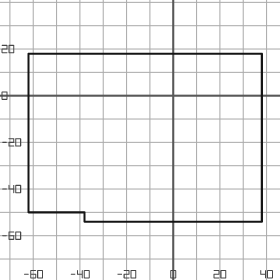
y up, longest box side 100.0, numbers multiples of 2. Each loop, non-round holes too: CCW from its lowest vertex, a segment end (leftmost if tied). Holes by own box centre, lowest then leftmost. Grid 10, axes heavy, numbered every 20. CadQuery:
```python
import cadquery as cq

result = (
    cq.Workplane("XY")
    .moveTo(-38.0, -54.0)
    .lineTo(38.0, -54.0)
    .lineTo(38.0, 18.0)
    .lineTo(-62.0, 18.0)
    .lineTo(-62.0, -50.0)
    .lineTo(-38.0, -50.0)
    .close()
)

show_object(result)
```